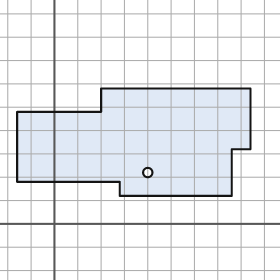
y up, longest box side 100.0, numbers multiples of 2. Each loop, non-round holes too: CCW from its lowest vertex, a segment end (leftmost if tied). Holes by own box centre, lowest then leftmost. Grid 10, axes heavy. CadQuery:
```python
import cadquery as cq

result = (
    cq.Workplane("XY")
    .moveTo(28.0, 12.0)
    .lineTo(76.0, 12.0)
    .lineTo(76.0, 32.0)
    .lineTo(84.0, 32.0)
    .lineTo(84.0, 58.0)
    .lineTo(20.0, 58.0)
    .lineTo(20.0, 48.0)
    .lineTo(-16.0, 48.0)
    .lineTo(-16.0, 18.0)
    .lineTo(28.0, 18.0)
    .close()
    .moveTo(40.0, 22.0)
    .circle(2.0)
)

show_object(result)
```